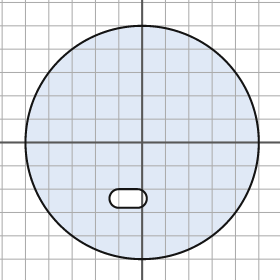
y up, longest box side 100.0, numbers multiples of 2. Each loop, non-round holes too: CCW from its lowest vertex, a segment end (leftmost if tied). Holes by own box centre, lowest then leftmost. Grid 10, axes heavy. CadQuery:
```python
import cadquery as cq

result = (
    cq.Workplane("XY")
    .moveTo(0.0, 0.0)
    .circle(50.0)
    .moveTo(-10.0, -28.0)
    .lineTo(-2.0, -28.0)
    .threePointArc((2.0, -24.0), (-2.0, -20.0))
    .lineTo(-10.0, -20.0)
    .threePointArc((-14.0, -24.0), (-10.0, -28.0))
    .close()
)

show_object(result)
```